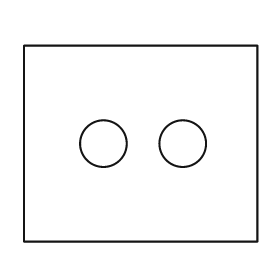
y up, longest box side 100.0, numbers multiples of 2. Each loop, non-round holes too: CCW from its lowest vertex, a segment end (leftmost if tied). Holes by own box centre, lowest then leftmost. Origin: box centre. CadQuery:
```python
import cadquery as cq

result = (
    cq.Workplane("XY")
    .moveTo(-50.0, -42.0)
    .lineTo(50.0, -42.0)
    .lineTo(50.0, 42.0)
    .lineTo(-50.0, 42.0)
    .close()
    .moveTo(-16.0, 0.0)
    .circle(10.0)
    .moveTo(18.0, 0.0)
    .circle(10.0)
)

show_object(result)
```